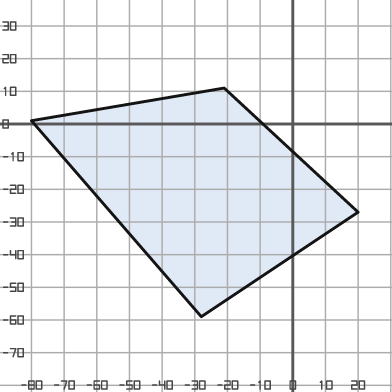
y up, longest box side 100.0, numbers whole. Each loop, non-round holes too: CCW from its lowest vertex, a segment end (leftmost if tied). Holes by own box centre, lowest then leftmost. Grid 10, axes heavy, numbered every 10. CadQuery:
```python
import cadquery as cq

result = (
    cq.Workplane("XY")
    .moveTo(-28.0, -59.0)
    .lineTo(20.0, -27.0)
    .lineTo(-21.0, 11.0)
    .lineTo(-80.0, 1.0)
    .close()
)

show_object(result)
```